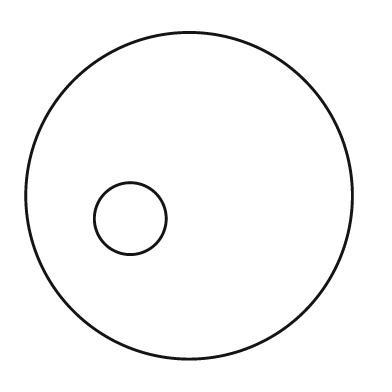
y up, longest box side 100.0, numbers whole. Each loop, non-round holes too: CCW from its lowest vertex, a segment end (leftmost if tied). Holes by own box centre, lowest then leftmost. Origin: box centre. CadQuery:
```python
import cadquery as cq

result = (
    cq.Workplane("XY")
    .moveTo(0.0, 0.0)
    .circle(50.0)
    .moveTo(-18.0, -7.0)
    .circle(11.0)
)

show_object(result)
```